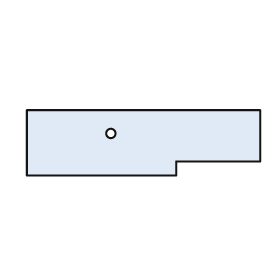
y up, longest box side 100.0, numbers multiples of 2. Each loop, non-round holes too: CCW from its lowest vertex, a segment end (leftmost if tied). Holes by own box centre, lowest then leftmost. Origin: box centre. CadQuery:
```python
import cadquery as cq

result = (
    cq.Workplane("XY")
    .moveTo(-50.0, -14.0)
    .lineTo(14.0, -14.0)
    .lineTo(14.0, -8.0)
    .lineTo(50.0, -8.0)
    .lineTo(50.0, 14.0)
    .lineTo(-50.0, 14.0)
    .close()
    .moveTo(-14.0, 4.0)
    .circle(2.0)
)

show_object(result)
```